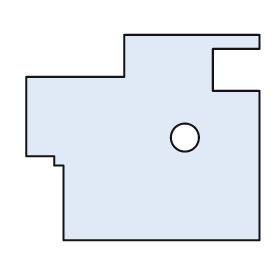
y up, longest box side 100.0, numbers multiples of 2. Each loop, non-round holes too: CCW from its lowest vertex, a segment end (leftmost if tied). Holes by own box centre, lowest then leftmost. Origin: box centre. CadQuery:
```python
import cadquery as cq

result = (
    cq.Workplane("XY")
    .moveTo(-34.0, -44.0)
    .lineTo(50.0, -44.0)
    .lineTo(50.0, 20.0)
    .lineTo(30.0, 20.0)
    .lineTo(30.0, 38.0)
    .lineTo(50.0, 38.0)
    .lineTo(50.0, 44.0)
    .lineTo(-8.0, 44.0)
    .lineTo(-8.0, 26.0)
    .lineTo(-50.0, 26.0)
    .lineTo(-50.0, -8.0)
    .lineTo(-38.0, -8.0)
    .lineTo(-38.0, -12.0)
    .lineTo(-34.0, -12.0)
    .close()
    .moveTo(18.0, 0.0)
    .circle(6.0)
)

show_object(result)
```